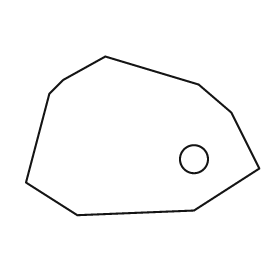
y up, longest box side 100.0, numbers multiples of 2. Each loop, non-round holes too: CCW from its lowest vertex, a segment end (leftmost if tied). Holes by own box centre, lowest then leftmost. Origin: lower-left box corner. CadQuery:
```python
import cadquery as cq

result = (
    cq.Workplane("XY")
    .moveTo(22.0, 0.0)
    .lineTo(72.0, 2.0)
    .lineTo(100.0, 20.0)
    .lineTo(88.0, 44.0)
    .lineTo(74.0, 56.0)
    .lineTo(34.0, 68.0)
    .lineTo(16.0, 58.0)
    .lineTo(10.0, 52.0)
    .lineTo(0.0, 14.0)
    .close()
    .moveTo(72.0, 24.0)
    .circle(6.0)
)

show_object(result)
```